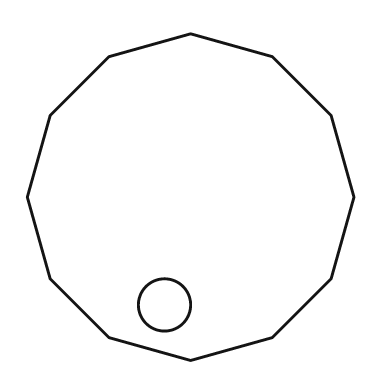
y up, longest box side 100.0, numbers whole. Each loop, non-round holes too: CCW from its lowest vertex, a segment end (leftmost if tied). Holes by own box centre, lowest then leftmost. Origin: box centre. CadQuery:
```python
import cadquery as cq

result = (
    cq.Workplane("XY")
    .moveTo(0.0, -50.0)
    .lineTo(25.0, -43.0)
    .lineTo(43.0, -25.0)
    .lineTo(50.0, 0.0)
    .lineTo(43.0, 25.0)
    .lineTo(25.0, 43.0)
    .lineTo(0.0, 50.0)
    .lineTo(-25.0, 43.0)
    .lineTo(-43.0, 25.0)
    .lineTo(-50.0, 0.0)
    .lineTo(-43.0, -25.0)
    .lineTo(-25.0, -43.0)
    .close()
    .moveTo(-8.0, -33.0)
    .circle(8.0)
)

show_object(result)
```